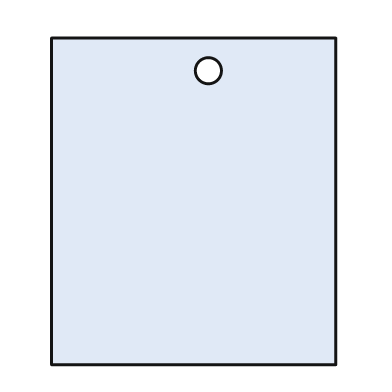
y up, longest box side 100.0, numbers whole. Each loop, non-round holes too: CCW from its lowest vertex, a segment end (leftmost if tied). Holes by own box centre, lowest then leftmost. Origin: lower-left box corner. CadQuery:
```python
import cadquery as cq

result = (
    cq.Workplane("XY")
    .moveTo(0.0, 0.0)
    .lineTo(87.0, 0.0)
    .lineTo(87.0, 100.0)
    .lineTo(0.0, 100.0)
    .close()
    .moveTo(48.0, 90.0)
    .circle(4.0)
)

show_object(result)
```